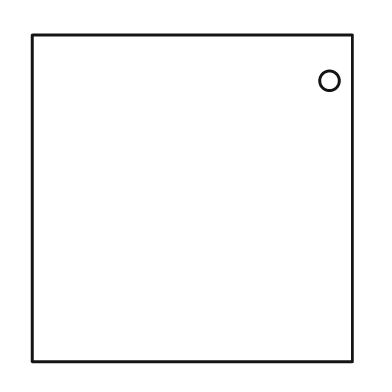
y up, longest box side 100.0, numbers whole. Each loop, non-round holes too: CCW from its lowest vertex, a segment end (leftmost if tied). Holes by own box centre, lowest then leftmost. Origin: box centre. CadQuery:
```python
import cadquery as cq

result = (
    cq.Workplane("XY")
    .moveTo(-49.0, -50.0)
    .lineTo(49.0, -50.0)
    .lineTo(49.0, 50.0)
    .lineTo(-49.0, 50.0)
    .close()
    .moveTo(42.0, 36.0)
    .circle(3.0)
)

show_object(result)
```